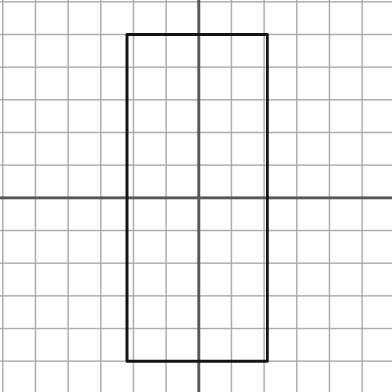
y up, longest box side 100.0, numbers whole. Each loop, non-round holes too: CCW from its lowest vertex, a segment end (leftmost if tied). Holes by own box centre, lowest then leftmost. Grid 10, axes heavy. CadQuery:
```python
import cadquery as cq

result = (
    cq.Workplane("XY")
    .moveTo(-22.0, -50.0)
    .lineTo(21.0, -50.0)
    .lineTo(21.0, 50.0)
    .lineTo(-22.0, 50.0)
    .close()
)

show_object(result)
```